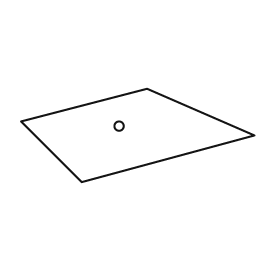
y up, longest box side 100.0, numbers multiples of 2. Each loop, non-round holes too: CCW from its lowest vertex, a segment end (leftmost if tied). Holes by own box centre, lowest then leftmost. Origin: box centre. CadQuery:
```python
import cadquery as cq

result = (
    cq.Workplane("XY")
    .moveTo(-24.0, -20.0)
    .lineTo(50.0, 0.0)
    .lineTo(4.0, 20.0)
    .lineTo(-50.0, 6.0)
    .close()
    .moveTo(-8.0, 4.0)
    .circle(2.0)
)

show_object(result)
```